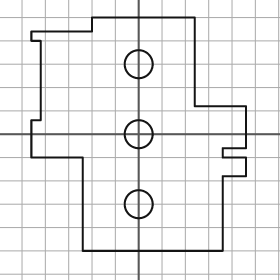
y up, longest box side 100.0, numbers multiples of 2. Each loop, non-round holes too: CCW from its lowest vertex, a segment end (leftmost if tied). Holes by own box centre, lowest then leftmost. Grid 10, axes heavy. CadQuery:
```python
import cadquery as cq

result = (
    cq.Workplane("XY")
    .moveTo(-24.0, -50.0)
    .lineTo(36.0, -50.0)
    .lineTo(36.0, -18.0)
    .lineTo(46.0, -18.0)
    .lineTo(46.0, -10.0)
    .lineTo(36.0, -10.0)
    .lineTo(36.0, -6.0)
    .lineTo(46.0, -6.0)
    .lineTo(46.0, 12.0)
    .lineTo(24.0, 12.0)
    .lineTo(24.0, 50.0)
    .lineTo(-20.0, 50.0)
    .lineTo(-20.0, 44.0)
    .lineTo(-46.0, 44.0)
    .lineTo(-46.0, 40.0)
    .lineTo(-42.0, 40.0)
    .lineTo(-42.0, 6.0)
    .lineTo(-46.0, 6.0)
    .lineTo(-46.0, -10.0)
    .lineTo(-24.0, -10.0)
    .close()
    .moveTo(0.0, -30.0)
    .circle(6.0)
    .moveTo(0.0, 0.0)
    .circle(6.0)
    .moveTo(0.0, 30.0)
    .circle(6.0)
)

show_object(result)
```